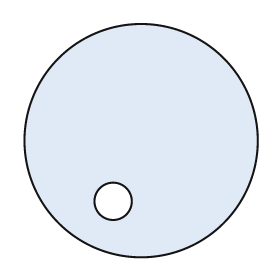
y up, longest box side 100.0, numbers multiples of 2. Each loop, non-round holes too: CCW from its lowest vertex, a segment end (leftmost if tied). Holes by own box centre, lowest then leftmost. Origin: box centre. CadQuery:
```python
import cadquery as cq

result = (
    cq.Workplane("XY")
    .moveTo(0.0, 0.0)
    .circle(50.0)
    .moveTo(-12.0, -26.0)
    .circle(8.0)
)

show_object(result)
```